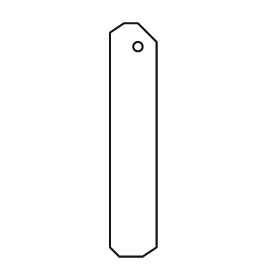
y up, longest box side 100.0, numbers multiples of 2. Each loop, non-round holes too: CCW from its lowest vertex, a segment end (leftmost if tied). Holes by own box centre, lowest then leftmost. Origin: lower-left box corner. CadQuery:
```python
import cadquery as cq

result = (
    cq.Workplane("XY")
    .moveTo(4.0, 0.0)
    .lineTo(14.0, 0.0)
    .lineTo(20.0, 4.0)
    .lineTo(20.0, 92.0)
    .lineTo(12.0, 100.0)
    .lineTo(6.0, 100.0)
    .lineTo(0.0, 96.0)
    .lineTo(0.0, 4.0)
    .close()
    .moveTo(12.0, 90.0)
    .circle(2.0)
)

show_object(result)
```